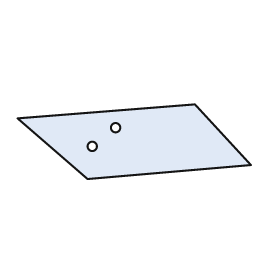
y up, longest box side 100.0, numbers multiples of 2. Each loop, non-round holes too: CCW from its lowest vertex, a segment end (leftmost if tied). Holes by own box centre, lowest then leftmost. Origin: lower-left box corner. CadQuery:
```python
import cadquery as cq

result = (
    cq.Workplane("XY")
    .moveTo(30.0, 0.0)
    .lineTo(100.0, 6.0)
    .lineTo(76.0, 32.0)
    .lineTo(0.0, 26.0)
    .close()
    .moveTo(32.0, 14.0)
    .circle(2.0)
    .moveTo(42.0, 22.0)
    .circle(2.0)
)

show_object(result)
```